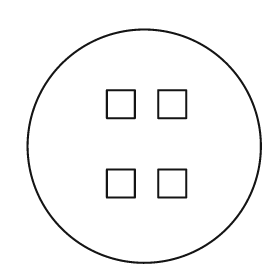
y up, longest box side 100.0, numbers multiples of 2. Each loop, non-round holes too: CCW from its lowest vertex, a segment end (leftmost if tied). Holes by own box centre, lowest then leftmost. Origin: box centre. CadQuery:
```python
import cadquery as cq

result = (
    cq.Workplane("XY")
    .moveTo(0.0, 0.0)
    .circle(50.0)
    .moveTo(-16.0, -22.0)
    .lineTo(-4.0, -22.0)
    .lineTo(-4.0, -10.0)
    .lineTo(-16.0, -10.0)
    .close()
    .moveTo(6.0, -22.0)
    .lineTo(18.0, -22.0)
    .lineTo(18.0, -10.0)
    .lineTo(6.0, -10.0)
    .close()
    .moveTo(-16.0, 12.0)
    .lineTo(-4.0, 12.0)
    .lineTo(-4.0, 24.0)
    .lineTo(-16.0, 24.0)
    .close()
    .moveTo(6.0, 12.0)
    .lineTo(18.0, 12.0)
    .lineTo(18.0, 24.0)
    .lineTo(6.0, 24.0)
    .close()
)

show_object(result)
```